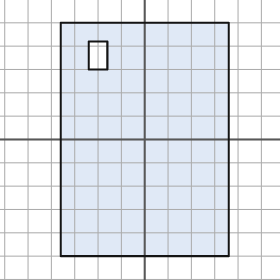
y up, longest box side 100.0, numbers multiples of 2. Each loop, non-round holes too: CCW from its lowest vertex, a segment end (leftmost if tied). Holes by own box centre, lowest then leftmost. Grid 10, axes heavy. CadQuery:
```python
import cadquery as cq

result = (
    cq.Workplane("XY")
    .moveTo(-36.0, -50.0)
    .lineTo(36.0, -50.0)
    .lineTo(36.0, 50.0)
    .lineTo(-36.0, 50.0)
    .close()
    .moveTo(-24.0, 30.0)
    .lineTo(-16.0, 30.0)
    .lineTo(-16.0, 42.0)
    .lineTo(-24.0, 42.0)
    .close()
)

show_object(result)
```